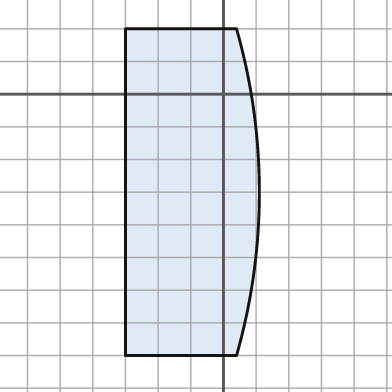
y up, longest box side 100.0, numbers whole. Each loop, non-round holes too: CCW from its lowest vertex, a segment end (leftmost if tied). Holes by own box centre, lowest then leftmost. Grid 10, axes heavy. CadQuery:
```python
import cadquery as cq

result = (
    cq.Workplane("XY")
    .moveTo(-30.0, -80.0)
    .lineTo(4.0, -80.0)
    .threePointArc((11.0, -30.0), (4.0, 20.0))
    .lineTo(-30.0, 20.0)
    .close()
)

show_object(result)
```